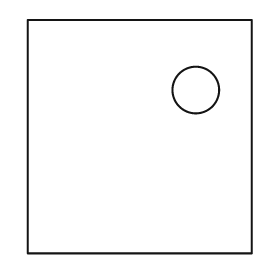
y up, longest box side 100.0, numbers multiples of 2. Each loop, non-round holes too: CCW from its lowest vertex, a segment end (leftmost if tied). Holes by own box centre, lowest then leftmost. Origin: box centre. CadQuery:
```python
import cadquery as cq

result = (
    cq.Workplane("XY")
    .moveTo(-48.0, -50.0)
    .lineTo(48.0, -50.0)
    .lineTo(48.0, 50.0)
    .lineTo(-48.0, 50.0)
    .close()
    .moveTo(24.0, 20.0)
    .circle(10.0)
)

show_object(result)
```